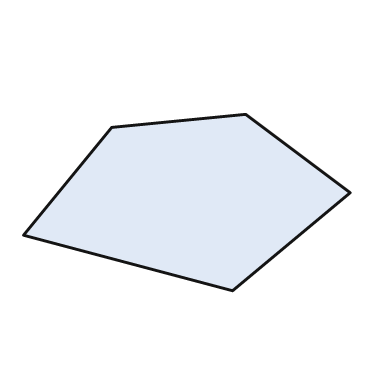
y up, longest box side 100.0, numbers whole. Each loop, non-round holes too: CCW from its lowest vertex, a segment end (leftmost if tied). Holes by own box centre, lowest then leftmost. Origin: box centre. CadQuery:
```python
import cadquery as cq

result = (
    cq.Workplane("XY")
    .moveTo(14.0, -27.0)
    .lineTo(50.0, 3.0)
    .lineTo(18.0, 27.0)
    .lineTo(-23.0, 23.0)
    .lineTo(-50.0, -10.0)
    .close()
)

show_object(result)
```